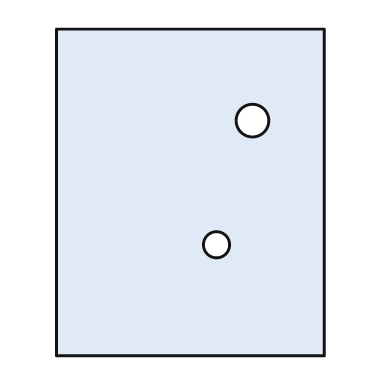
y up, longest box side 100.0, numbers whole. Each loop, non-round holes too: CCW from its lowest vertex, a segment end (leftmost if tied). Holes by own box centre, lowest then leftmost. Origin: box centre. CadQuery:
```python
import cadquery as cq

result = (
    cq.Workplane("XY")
    .moveTo(-41.0, -50.0)
    .lineTo(41.0, -50.0)
    .lineTo(41.0, 50.0)
    .lineTo(-41.0, 50.0)
    .close()
    .moveTo(8.0, -16.0)
    .circle(4.0)
    .moveTo(19.0, 22.0)
    .circle(5.0)
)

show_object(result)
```